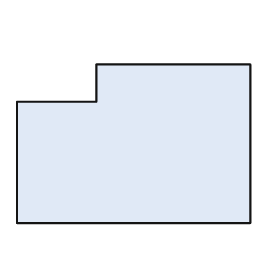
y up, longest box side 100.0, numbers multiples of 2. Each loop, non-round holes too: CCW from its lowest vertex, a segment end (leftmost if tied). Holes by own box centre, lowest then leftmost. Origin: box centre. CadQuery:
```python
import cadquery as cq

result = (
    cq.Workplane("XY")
    .moveTo(-50.0, -34.0)
    .lineTo(50.0, -34.0)
    .lineTo(50.0, 34.0)
    .lineTo(-16.0, 34.0)
    .lineTo(-16.0, 18.0)
    .lineTo(-50.0, 18.0)
    .close()
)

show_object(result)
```